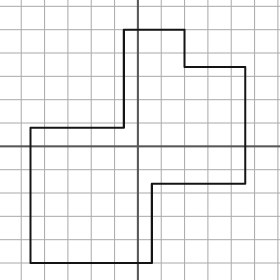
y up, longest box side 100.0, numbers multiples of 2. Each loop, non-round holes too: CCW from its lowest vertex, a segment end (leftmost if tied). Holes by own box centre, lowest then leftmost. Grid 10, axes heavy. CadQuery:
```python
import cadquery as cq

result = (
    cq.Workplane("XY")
    .moveTo(-46.0, -50.0)
    .lineTo(6.0, -50.0)
    .lineTo(6.0, -16.0)
    .lineTo(46.0, -16.0)
    .lineTo(46.0, 34.0)
    .lineTo(20.0, 34.0)
    .lineTo(20.0, 50.0)
    .lineTo(-6.0, 50.0)
    .lineTo(-6.0, 8.0)
    .lineTo(-46.0, 8.0)
    .close()
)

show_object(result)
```